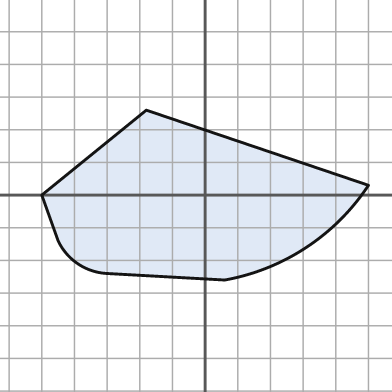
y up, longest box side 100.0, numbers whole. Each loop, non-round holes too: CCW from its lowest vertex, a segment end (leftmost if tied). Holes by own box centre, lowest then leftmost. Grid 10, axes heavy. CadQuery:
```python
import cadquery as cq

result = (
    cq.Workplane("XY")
    .moveTo(6.0, -26.0)
    .threePointArc((31.0, -16.0), (50.0, 3.0))
    .lineTo(-18.0, 26.0)
    .lineTo(-50.0, 0.0)
    .lineTo(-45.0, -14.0)
    .threePointArc((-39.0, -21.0), (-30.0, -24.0))
    .close()
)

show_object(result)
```